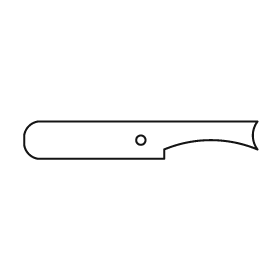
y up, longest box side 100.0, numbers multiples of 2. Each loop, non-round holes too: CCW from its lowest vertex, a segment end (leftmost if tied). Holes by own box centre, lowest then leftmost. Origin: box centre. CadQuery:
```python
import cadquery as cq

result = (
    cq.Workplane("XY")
    .moveTo(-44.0, -8.0)
    .lineTo(10.0, -8.0)
    .lineTo(10.0, -4.0)
    .threePointArc((30.0, 0.0), (50.0, -4.0))
    .threePointArc((48.0, 2.0), (50.0, 8.0))
    .lineTo(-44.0, 8.0)
    .threePointArc((-48.0, 6.0), (-50.0, 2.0))
    .lineTo(-50.0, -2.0)
    .threePointArc((-48.0, -6.0), (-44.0, -8.0))
    .close()
    .moveTo(0.0, 0.0)
    .circle(2.0)
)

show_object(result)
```